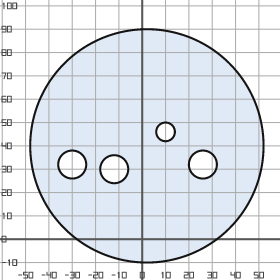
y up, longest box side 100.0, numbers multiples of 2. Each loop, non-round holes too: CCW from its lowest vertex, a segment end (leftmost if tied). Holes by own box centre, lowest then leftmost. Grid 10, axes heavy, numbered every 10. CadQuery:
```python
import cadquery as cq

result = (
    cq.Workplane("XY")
    .moveTo(2.0, 40.0)
    .circle(50.0)
    .moveTo(-12.0, 30.0)
    .circle(6.0)
    .moveTo(-30.0, 32.0)
    .circle(6.0)
    .moveTo(26.0, 32.0)
    .circle(6.0)
    .moveTo(10.0, 46.0)
    .circle(4.0)
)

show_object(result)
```